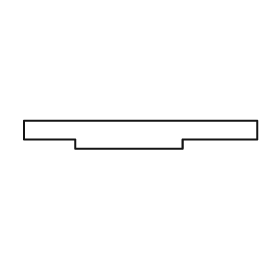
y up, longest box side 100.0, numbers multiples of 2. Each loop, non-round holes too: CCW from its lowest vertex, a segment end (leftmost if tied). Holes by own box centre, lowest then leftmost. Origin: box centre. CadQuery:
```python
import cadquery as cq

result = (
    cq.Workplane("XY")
    .moveTo(-28.0, -6.0)
    .lineTo(18.0, -6.0)
    .lineTo(18.0, -2.0)
    .lineTo(50.0, -2.0)
    .lineTo(50.0, 6.0)
    .lineTo(-50.0, 6.0)
    .lineTo(-50.0, -2.0)
    .lineTo(-28.0, -2.0)
    .close()
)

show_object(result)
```